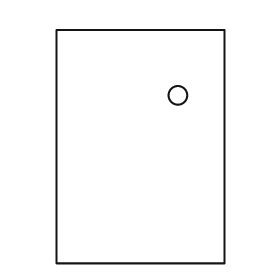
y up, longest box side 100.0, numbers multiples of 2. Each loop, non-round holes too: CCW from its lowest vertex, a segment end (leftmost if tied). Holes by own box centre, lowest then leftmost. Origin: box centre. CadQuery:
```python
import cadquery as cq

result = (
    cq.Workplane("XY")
    .moveTo(-36.0, -50.0)
    .lineTo(36.0, -50.0)
    .lineTo(36.0, 50.0)
    .lineTo(-36.0, 50.0)
    .close()
    .moveTo(16.0, 22.0)
    .circle(4.0)
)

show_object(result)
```